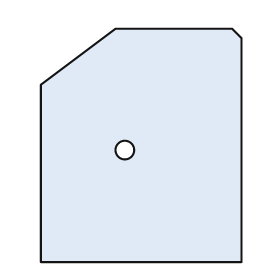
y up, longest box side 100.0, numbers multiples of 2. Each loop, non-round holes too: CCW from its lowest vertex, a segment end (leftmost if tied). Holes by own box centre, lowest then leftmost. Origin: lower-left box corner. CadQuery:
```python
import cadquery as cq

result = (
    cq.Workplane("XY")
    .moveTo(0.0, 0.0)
    .lineTo(86.0, 0.0)
    .lineTo(86.0, 96.0)
    .lineTo(82.0, 100.0)
    .lineTo(32.0, 100.0)
    .lineTo(0.0, 76.0)
    .close()
    .moveTo(36.0, 48.0)
    .circle(4.0)
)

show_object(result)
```